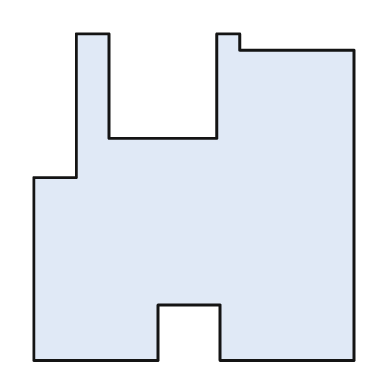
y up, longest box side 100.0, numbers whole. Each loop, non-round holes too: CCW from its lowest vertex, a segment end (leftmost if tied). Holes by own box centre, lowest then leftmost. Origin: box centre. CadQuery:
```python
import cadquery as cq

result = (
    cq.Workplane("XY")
    .moveTo(-49.0, -50.0)
    .lineTo(-11.0, -50.0)
    .lineTo(-11.0, -33.0)
    .lineTo(8.0, -33.0)
    .lineTo(8.0, -50.0)
    .lineTo(49.0, -50.0)
    .lineTo(49.0, 45.0)
    .lineTo(14.0, 45.0)
    .lineTo(14.0, 50.0)
    .lineTo(7.0, 50.0)
    .lineTo(7.0, 18.0)
    .lineTo(-26.0, 18.0)
    .lineTo(-26.0, 50.0)
    .lineTo(-36.0, 50.0)
    .lineTo(-36.0, 6.0)
    .lineTo(-49.0, 6.0)
    .close()
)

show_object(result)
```